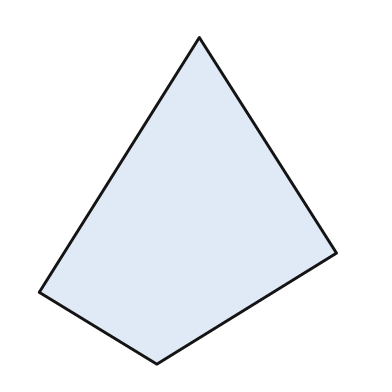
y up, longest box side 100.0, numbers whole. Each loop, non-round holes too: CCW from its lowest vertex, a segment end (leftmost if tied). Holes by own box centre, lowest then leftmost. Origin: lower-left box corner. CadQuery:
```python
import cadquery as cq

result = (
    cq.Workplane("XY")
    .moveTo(36.0, 0.0)
    .lineTo(91.0, 34.0)
    .lineTo(49.0, 100.0)
    .lineTo(0.0, 22.0)
    .close()
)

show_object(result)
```